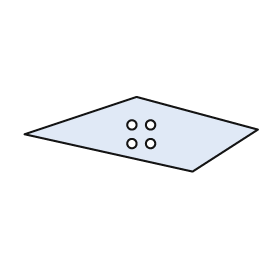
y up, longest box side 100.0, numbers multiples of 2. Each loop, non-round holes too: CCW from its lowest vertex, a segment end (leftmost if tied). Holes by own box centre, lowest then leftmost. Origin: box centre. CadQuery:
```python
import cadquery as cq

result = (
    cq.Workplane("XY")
    .moveTo(22.0, -16.0)
    .lineTo(50.0, 2.0)
    .lineTo(-2.0, 16.0)
    .lineTo(-50.0, 0.0)
    .close()
    .moveTo(-4.0, -4.0)
    .circle(2.0)
    .moveTo(4.0, -4.0)
    .circle(2.0)
    .moveTo(-4.0, 4.0)
    .circle(2.0)
    .moveTo(4.0, 4.0)
    .circle(2.0)
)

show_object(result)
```